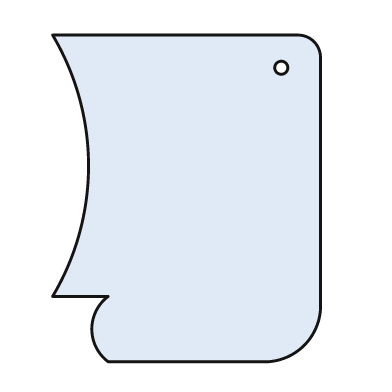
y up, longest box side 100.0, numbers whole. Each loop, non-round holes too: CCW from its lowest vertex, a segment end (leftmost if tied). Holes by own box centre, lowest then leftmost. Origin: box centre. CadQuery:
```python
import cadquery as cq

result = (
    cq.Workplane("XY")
    .moveTo(-24.0, -50.0)
    .lineTo(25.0, -50.0)
    .threePointArc((36.0, -45.0), (41.0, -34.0))
    .lineTo(41.0, 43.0)
    .threePointArc((39.0, 48.0), (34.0, 50.0))
    .lineTo(-41.0, 50.0)
    .threePointArc((-30.0, 10.0), (-41.0, -30.0))
    .lineTo(-24.0, -30.0)
    .threePointArc((-29.0, -40.0), (-24.0, -50.0))
    .close()
    .moveTo(29.0, 40.0)
    .circle(2.0)
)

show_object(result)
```